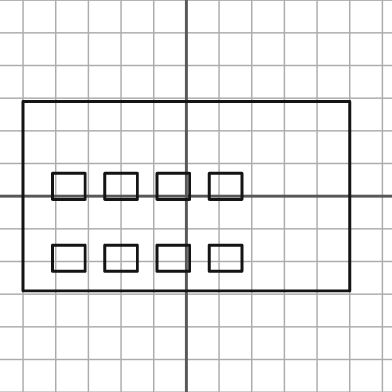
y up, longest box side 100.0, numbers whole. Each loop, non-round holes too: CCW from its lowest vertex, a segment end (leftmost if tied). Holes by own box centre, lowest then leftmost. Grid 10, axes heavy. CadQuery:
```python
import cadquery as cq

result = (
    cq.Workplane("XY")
    .moveTo(-50.0, -29.0)
    .lineTo(50.0, -29.0)
    .lineTo(50.0, 29.0)
    .lineTo(-50.0, 29.0)
    .close()
    .moveTo(-41.0, -23.0)
    .lineTo(-31.0, -23.0)
    .lineTo(-31.0, -15.0)
    .lineTo(-41.0, -15.0)
    .close()
    .moveTo(-25.0, -23.0)
    .lineTo(-15.0, -23.0)
    .lineTo(-15.0, -15.0)
    .lineTo(-25.0, -15.0)
    .close()
    .moveTo(-9.0, -23.0)
    .lineTo(1.0, -23.0)
    .lineTo(1.0, -15.0)
    .lineTo(-9.0, -15.0)
    .close()
    .moveTo(7.0, -23.0)
    .lineTo(17.0, -23.0)
    .lineTo(17.0, -15.0)
    .lineTo(7.0, -15.0)
    .close()
    .moveTo(-41.0, -1.0)
    .lineTo(-31.0, -1.0)
    .lineTo(-31.0, 7.0)
    .lineTo(-41.0, 7.0)
    .close()
    .moveTo(-25.0, -1.0)
    .lineTo(-15.0, -1.0)
    .lineTo(-15.0, 7.0)
    .lineTo(-25.0, 7.0)
    .close()
    .moveTo(-9.0, -1.0)
    .lineTo(1.0, -1.0)
    .lineTo(1.0, 7.0)
    .lineTo(-9.0, 7.0)
    .close()
    .moveTo(7.0, -1.0)
    .lineTo(17.0, -1.0)
    .lineTo(17.0, 7.0)
    .lineTo(7.0, 7.0)
    .close()
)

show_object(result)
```